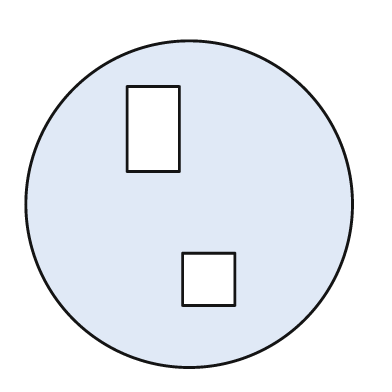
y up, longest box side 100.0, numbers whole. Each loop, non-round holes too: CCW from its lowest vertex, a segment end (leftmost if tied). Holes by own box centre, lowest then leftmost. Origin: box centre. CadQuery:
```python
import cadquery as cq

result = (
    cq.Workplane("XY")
    .moveTo(0.0, 0.0)
    .circle(50.0)
    .moveTo(-2.0, -31.0)
    .lineTo(14.0, -31.0)
    .lineTo(14.0, -15.0)
    .lineTo(-2.0, -15.0)
    .close()
    .moveTo(-19.0, 10.0)
    .lineTo(-3.0, 10.0)
    .lineTo(-3.0, 36.0)
    .lineTo(-19.0, 36.0)
    .close()
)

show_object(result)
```